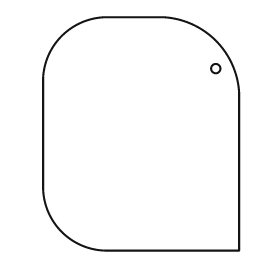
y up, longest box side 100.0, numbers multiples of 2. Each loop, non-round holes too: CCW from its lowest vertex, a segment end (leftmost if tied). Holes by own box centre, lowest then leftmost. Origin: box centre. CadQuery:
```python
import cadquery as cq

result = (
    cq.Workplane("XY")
    .moveTo(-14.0, -50.0)
    .lineTo(42.0, -50.0)
    .lineTo(42.0, 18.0)
    .threePointArc((32.0, 40.0), (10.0, 50.0))
    .lineTo(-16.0, 50.0)
    .threePointArc((-34.0, 42.0), (-42.0, 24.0))
    .lineTo(-42.0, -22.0)
    .threePointArc((-34.0, -42.0), (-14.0, -50.0))
    .close()
    .moveTo(32.0, 28.0)
    .circle(2.0)
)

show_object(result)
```